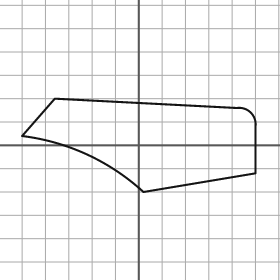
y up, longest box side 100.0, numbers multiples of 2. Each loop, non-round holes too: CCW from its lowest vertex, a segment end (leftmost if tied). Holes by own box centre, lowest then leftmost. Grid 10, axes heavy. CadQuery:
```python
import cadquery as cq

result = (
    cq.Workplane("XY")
    .moveTo(2.0, -20.0)
    .lineTo(50.0, -12.0)
    .lineTo(50.0, 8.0)
    .threePointArc((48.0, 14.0), (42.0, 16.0))
    .lineTo(-36.0, 20.0)
    .lineTo(-50.0, 4.0)
    .threePointArc((-22.0, -4.0), (2.0, -20.0))
    .close()
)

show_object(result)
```